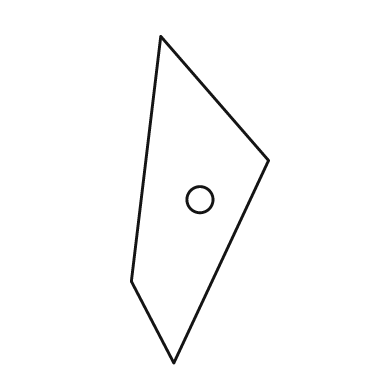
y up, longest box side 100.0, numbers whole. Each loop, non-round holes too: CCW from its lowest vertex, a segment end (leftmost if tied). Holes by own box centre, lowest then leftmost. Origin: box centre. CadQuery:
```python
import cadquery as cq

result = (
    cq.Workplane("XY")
    .moveTo(-8.0, -50.0)
    .lineTo(21.0, 12.0)
    .lineTo(-12.0, 50.0)
    .lineTo(-21.0, -25.0)
    .close()
    .moveTo(0.0, 0.0)
    .circle(4.0)
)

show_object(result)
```